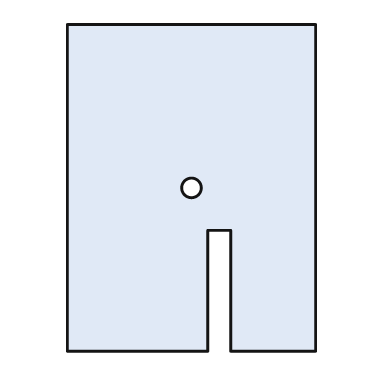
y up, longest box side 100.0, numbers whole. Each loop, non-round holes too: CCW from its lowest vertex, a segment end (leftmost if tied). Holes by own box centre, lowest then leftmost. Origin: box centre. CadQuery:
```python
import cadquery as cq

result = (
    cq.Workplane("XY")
    .moveTo(-38.0, -50.0)
    .lineTo(5.0, -50.0)
    .lineTo(5.0, -13.0)
    .lineTo(12.0, -13.0)
    .lineTo(12.0, -50.0)
    .lineTo(38.0, -50.0)
    .lineTo(38.0, 50.0)
    .lineTo(-38.0, 50.0)
    .close()
    .moveTo(0.0, 0.0)
    .circle(3.0)
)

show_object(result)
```